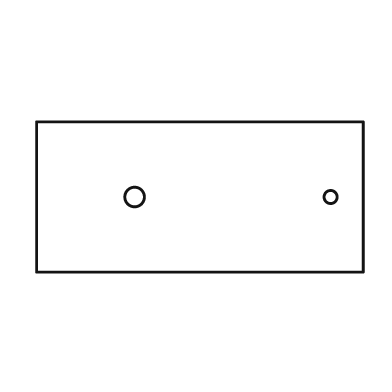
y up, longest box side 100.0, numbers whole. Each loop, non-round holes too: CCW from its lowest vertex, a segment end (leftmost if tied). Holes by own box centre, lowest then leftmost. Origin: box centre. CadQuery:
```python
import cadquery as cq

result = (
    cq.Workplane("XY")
    .moveTo(-50.0, -23.0)
    .lineTo(50.0, -23.0)
    .lineTo(50.0, 23.0)
    .lineTo(-50.0, 23.0)
    .close()
    .moveTo(-20.0, 0.0)
    .circle(3.0)
    .moveTo(40.0, 0.0)
    .circle(2.0)
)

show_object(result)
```